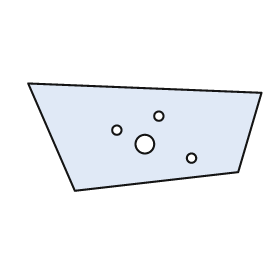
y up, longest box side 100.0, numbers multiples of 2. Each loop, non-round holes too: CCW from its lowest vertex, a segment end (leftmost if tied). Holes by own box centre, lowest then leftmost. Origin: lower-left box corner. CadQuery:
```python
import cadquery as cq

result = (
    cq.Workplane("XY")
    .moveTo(20.0, 0.0)
    .lineTo(90.0, 8.0)
    .lineTo(100.0, 42.0)
    .lineTo(0.0, 46.0)
    .close()
    .moveTo(70.0, 14.0)
    .circle(2.0)
    .moveTo(50.0, 20.0)
    .circle(4.0)
    .moveTo(38.0, 26.0)
    .circle(2.0)
    .moveTo(56.0, 32.0)
    .circle(2.0)
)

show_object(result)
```